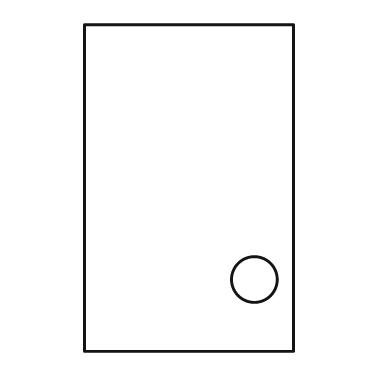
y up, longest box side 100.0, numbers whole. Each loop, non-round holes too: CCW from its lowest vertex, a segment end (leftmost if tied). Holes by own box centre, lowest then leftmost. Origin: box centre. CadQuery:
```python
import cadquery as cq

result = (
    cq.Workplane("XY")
    .moveTo(-32.0, -50.0)
    .lineTo(32.0, -50.0)
    .lineTo(32.0, 50.0)
    .lineTo(-32.0, 50.0)
    .close()
    .moveTo(20.0, -28.0)
    .circle(7.0)
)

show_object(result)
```